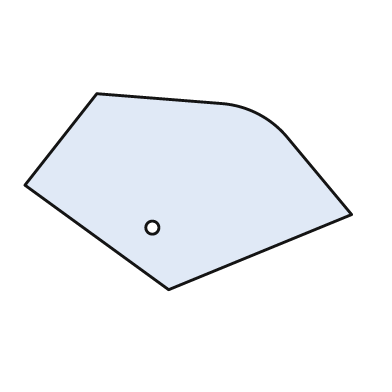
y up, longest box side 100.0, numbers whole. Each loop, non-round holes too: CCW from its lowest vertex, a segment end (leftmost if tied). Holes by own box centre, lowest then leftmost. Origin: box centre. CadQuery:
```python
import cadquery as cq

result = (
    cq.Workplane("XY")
    .moveTo(-6.0, -30.0)
    .lineTo(50.0, -7.0)
    .lineTo(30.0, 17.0)
    .threePointArc((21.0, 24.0), (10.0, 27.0))
    .lineTo(-28.0, 30.0)
    .lineTo(-50.0, 2.0)
    .close()
    .moveTo(-11.0, -11.0)
    .circle(2.0)
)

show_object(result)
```